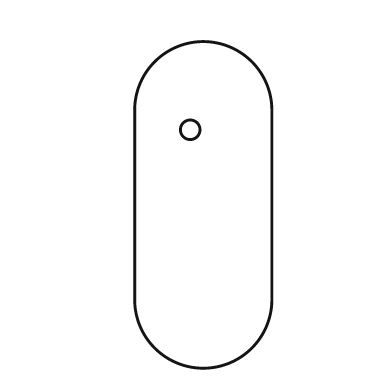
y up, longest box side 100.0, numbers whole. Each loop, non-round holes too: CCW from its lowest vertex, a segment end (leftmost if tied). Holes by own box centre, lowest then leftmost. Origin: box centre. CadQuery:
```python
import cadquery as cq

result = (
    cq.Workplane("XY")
    .moveTo(-21.0, -29.0)
    .threePointArc((0.0, -50.0), (21.0, -29.0))
    .lineTo(21.0, 29.0)
    .threePointArc((0.0, 50.0), (-21.0, 29.0))
    .close()
    .moveTo(-4.0, 23.0)
    .circle(3.0)
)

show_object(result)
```